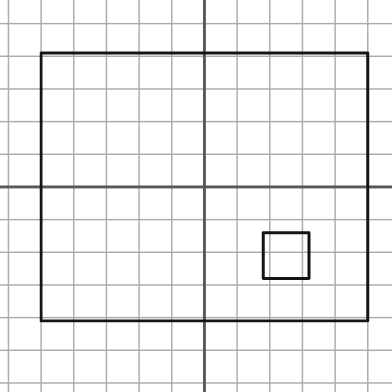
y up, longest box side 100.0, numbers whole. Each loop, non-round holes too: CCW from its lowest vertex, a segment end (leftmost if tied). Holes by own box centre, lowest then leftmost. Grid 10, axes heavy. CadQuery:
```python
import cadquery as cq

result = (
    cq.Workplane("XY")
    .moveTo(-50.0, -41.0)
    .lineTo(50.0, -41.0)
    .lineTo(50.0, 41.0)
    .lineTo(-50.0, 41.0)
    .close()
    .moveTo(18.0, -28.0)
    .lineTo(32.0, -28.0)
    .lineTo(32.0, -14.0)
    .lineTo(18.0, -14.0)
    .close()
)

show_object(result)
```